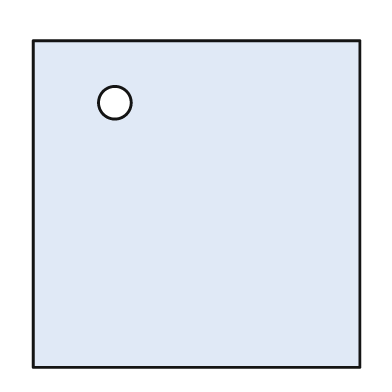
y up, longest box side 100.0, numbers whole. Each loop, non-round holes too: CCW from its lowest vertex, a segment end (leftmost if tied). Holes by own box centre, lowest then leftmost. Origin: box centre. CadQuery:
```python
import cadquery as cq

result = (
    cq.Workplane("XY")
    .moveTo(-50.0, -50.0)
    .lineTo(50.0, -50.0)
    .lineTo(50.0, 50.0)
    .lineTo(-50.0, 50.0)
    .close()
    .moveTo(-25.0, 31.0)
    .circle(5.0)
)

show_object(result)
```